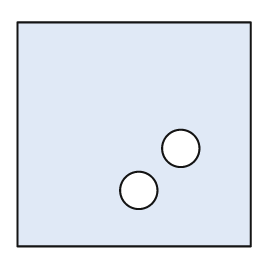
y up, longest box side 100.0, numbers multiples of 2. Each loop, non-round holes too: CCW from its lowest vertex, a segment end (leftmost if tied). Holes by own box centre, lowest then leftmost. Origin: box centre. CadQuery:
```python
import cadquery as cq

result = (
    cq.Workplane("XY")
    .moveTo(-50.0, -48.0)
    .lineTo(50.0, -48.0)
    .lineTo(50.0, 48.0)
    .lineTo(-50.0, 48.0)
    .close()
    .moveTo(2.0, -24.0)
    .circle(8.0)
    .moveTo(20.0, -6.0)
    .circle(8.0)
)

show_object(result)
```